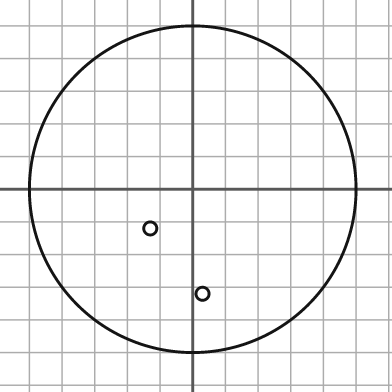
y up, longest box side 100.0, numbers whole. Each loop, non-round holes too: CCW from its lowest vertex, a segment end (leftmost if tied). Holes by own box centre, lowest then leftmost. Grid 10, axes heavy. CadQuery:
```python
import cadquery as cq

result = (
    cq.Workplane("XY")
    .moveTo(0.0, 0.0)
    .circle(50.0)
    .moveTo(3.0, -32.0)
    .circle(2.0)
    .moveTo(-13.0, -12.0)
    .circle(2.0)
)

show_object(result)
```